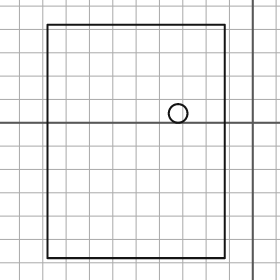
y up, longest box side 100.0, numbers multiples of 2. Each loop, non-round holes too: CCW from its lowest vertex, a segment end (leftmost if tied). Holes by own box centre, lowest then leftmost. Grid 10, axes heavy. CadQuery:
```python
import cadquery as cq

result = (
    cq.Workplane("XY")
    .moveTo(-88.0, -58.0)
    .lineTo(-12.0, -58.0)
    .lineTo(-12.0, 42.0)
    .lineTo(-88.0, 42.0)
    .close()
    .moveTo(-32.0, 4.0)
    .circle(4.0)
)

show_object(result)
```